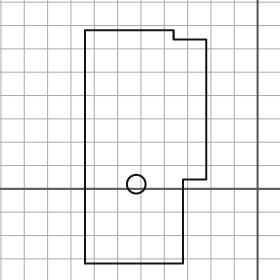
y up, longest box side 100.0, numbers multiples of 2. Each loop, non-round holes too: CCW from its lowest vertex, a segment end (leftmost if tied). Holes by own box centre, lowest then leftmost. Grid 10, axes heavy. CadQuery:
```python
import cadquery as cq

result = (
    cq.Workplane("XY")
    .moveTo(-74.0, -32.0)
    .lineTo(-32.0, -32.0)
    .lineTo(-32.0, 4.0)
    .lineTo(-22.0, 4.0)
    .lineTo(-22.0, 64.0)
    .lineTo(-36.0, 64.0)
    .lineTo(-36.0, 68.0)
    .lineTo(-74.0, 68.0)
    .close()
    .moveTo(-52.0, 2.0)
    .circle(4.0)
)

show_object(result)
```